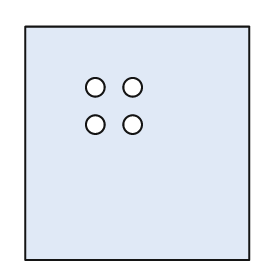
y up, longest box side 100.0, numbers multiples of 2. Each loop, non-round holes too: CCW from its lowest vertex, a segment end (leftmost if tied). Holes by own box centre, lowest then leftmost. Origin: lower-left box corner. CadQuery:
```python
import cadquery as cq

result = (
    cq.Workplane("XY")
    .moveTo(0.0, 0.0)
    .lineTo(96.0, 0.0)
    .lineTo(96.0, 100.0)
    .lineTo(0.0, 100.0)
    .close()
    .moveTo(30.0, 58.0)
    .circle(4.0)
    .moveTo(46.0, 58.0)
    .circle(4.0)
    .moveTo(30.0, 74.0)
    .circle(4.0)
    .moveTo(46.0, 74.0)
    .circle(4.0)
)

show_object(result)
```